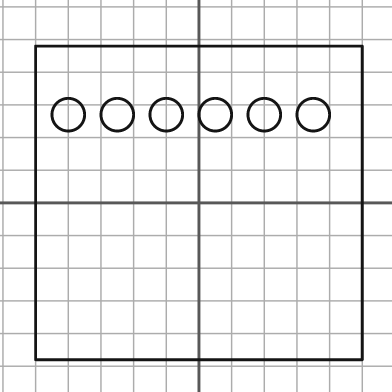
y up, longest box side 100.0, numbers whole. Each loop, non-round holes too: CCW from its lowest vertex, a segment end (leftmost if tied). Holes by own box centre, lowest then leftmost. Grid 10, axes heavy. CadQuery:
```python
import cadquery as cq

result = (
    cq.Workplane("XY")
    .moveTo(-50.0, -48.0)
    .lineTo(50.0, -48.0)
    .lineTo(50.0, 48.0)
    .lineTo(-50.0, 48.0)
    .close()
    .moveTo(-40.0, 27.0)
    .circle(5.0)
    .moveTo(-25.0, 27.0)
    .circle(5.0)
    .moveTo(-10.0, 27.0)
    .circle(5.0)
    .moveTo(5.0, 27.0)
    .circle(5.0)
    .moveTo(20.0, 27.0)
    .circle(5.0)
    .moveTo(35.0, 27.0)
    .circle(5.0)
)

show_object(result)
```